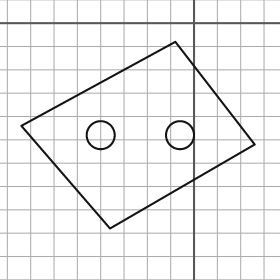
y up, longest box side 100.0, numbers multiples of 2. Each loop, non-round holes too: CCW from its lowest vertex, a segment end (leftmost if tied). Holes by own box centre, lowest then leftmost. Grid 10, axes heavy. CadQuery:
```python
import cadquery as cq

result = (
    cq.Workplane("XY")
    .moveTo(-36.0, -88.0)
    .lineTo(26.0, -52.0)
    .lineTo(-8.0, -8.0)
    .lineTo(-74.0, -44.0)
    .close()
    .moveTo(-40.0, -48.0)
    .circle(6.0)
    .moveTo(-6.0, -48.0)
    .circle(6.0)
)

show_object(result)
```